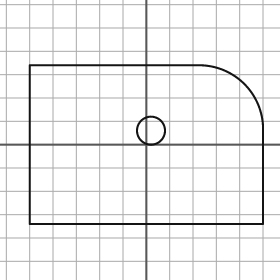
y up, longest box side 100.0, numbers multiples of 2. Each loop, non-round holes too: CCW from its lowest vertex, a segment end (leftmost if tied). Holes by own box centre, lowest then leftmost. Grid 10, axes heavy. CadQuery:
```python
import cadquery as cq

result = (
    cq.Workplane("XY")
    .moveTo(-50.0, -34.0)
    .lineTo(50.0, -34.0)
    .lineTo(50.0, 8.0)
    .threePointArc((42.0, 26.0), (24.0, 34.0))
    .lineTo(-50.0, 34.0)
    .close()
    .moveTo(2.0, 6.0)
    .circle(6.0)
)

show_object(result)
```